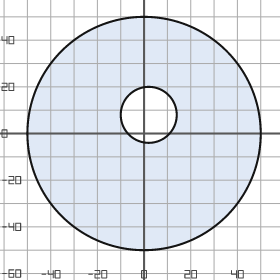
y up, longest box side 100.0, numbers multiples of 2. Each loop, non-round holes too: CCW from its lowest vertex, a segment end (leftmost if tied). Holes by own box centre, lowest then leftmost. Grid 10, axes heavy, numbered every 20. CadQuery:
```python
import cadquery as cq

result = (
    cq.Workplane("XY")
    .moveTo(0.0, 0.0)
    .circle(50.0)
    .moveTo(2.0, 8.0)
    .circle(12.0)
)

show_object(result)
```